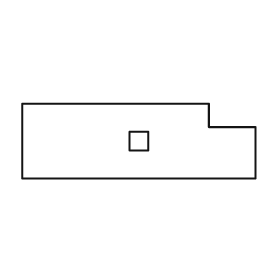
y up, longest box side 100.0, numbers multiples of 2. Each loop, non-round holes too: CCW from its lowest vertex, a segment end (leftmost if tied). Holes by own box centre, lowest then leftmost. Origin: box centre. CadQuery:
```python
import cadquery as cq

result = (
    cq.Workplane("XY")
    .moveTo(-50.0, -16.0)
    .lineTo(50.0, -16.0)
    .lineTo(50.0, 6.0)
    .lineTo(30.0, 6.0)
    .lineTo(30.0, 16.0)
    .lineTo(-50.0, 16.0)
    .close()
    .moveTo(-4.0, -4.0)
    .lineTo(4.0, -4.0)
    .lineTo(4.0, 4.0)
    .lineTo(-4.0, 4.0)
    .close()
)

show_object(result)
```